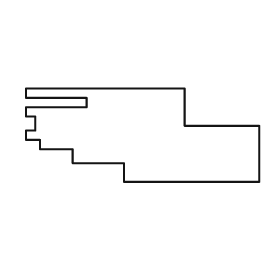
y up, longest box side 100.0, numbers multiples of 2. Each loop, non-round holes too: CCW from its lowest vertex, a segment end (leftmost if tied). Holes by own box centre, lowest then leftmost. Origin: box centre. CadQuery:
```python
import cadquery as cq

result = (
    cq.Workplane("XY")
    .moveTo(-8.0, -20.0)
    .lineTo(50.0, -20.0)
    .lineTo(50.0, 4.0)
    .lineTo(18.0, 4.0)
    .lineTo(18.0, 20.0)
    .lineTo(-50.0, 20.0)
    .lineTo(-50.0, 16.0)
    .lineTo(-24.0, 16.0)
    .lineTo(-24.0, 12.0)
    .lineTo(-50.0, 12.0)
    .lineTo(-50.0, 8.0)
    .lineTo(-46.0, 8.0)
    .lineTo(-46.0, 2.0)
    .lineTo(-50.0, 2.0)
    .lineTo(-50.0, -2.0)
    .lineTo(-44.0, -2.0)
    .lineTo(-44.0, -6.0)
    .lineTo(-30.0, -6.0)
    .lineTo(-30.0, -12.0)
    .lineTo(-8.0, -12.0)
    .close()
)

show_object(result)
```